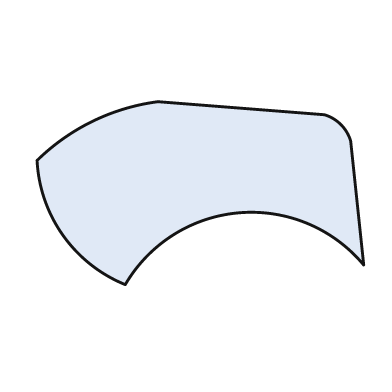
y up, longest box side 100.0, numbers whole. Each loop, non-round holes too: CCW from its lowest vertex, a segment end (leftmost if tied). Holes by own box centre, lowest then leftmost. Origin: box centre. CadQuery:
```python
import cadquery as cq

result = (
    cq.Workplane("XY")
    .moveTo(-23.0, -28.0)
    .threePointArc((12.0, -6.0), (50.0, -22.0))
    .lineTo(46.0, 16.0)
    .threePointArc((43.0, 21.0), (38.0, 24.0))
    .lineTo(-13.0, 28.0)
    .threePointArc((-33.0, 22.0), (-50.0, 10.0))
    .threePointArc((-42.0, -13.0), (-23.0, -28.0))
    .close()
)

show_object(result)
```